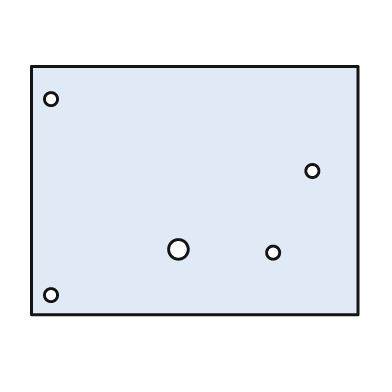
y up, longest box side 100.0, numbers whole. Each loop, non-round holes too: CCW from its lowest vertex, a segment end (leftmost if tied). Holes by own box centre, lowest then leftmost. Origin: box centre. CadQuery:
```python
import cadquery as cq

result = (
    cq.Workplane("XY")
    .moveTo(-50.0, -38.0)
    .lineTo(50.0, -38.0)
    .lineTo(50.0, 38.0)
    .lineTo(-50.0, 38.0)
    .close()
    .moveTo(-44.0, -32.0)
    .circle(2.0)
    .moveTo(24.0, -19.0)
    .circle(2.0)
    .moveTo(-5.0, -18.0)
    .circle(3.0)
    .moveTo(36.0, 6.0)
    .circle(2.0)
    .moveTo(-44.0, 28.0)
    .circle(2.0)
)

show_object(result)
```